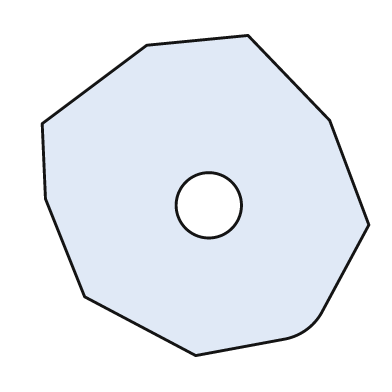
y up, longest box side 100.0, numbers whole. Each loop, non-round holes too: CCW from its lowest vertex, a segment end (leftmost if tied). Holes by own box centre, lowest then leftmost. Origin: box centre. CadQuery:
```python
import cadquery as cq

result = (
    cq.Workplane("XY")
    .moveTo(-3.0, -49.0)
    .lineTo(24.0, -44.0)
    .threePointArc((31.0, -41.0), (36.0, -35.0))
    .lineTo(50.0, -9.0)
    .lineTo(38.0, 23.0)
    .lineTo(13.0, 49.0)
    .lineTo(-18.0, 46.0)
    .lineTo(-50.0, 22.0)
    .lineTo(-49.0, -1.0)
    .lineTo(-37.0, -31.0)
    .close()
    .moveTo(1.0, -3.0)
    .circle(10.0)
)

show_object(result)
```